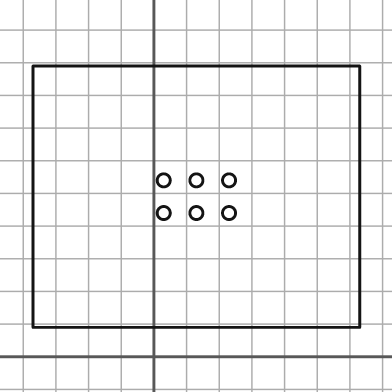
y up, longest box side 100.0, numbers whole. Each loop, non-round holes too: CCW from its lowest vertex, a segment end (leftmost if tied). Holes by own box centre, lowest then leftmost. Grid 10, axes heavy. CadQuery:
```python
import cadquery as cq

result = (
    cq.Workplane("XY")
    .moveTo(-37.0, 9.0)
    .lineTo(63.0, 9.0)
    .lineTo(63.0, 89.0)
    .lineTo(-37.0, 89.0)
    .close()
    .moveTo(3.0, 44.0)
    .circle(2.0)
    .moveTo(13.0, 44.0)
    .circle(2.0)
    .moveTo(23.0, 44.0)
    .circle(2.0)
    .moveTo(3.0, 54.0)
    .circle(2.0)
    .moveTo(13.0, 54.0)
    .circle(2.0)
    .moveTo(23.0, 54.0)
    .circle(2.0)
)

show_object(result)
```